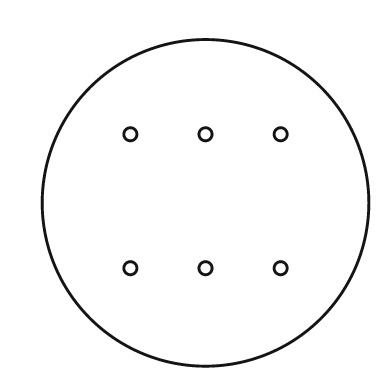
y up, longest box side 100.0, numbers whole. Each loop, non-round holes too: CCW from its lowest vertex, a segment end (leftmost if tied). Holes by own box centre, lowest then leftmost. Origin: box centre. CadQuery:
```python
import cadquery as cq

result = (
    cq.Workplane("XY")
    .moveTo(0.0, 0.0)
    .circle(50.0)
    .moveTo(-23.0, -20.0)
    .circle(2.0)
    .moveTo(0.0, -20.0)
    .circle(2.0)
    .moveTo(23.0, -20.0)
    .circle(2.0)
    .moveTo(-23.0, 21.0)
    .circle(2.0)
    .moveTo(0.0, 21.0)
    .circle(2.0)
    .moveTo(23.0, 21.0)
    .circle(2.0)
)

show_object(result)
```